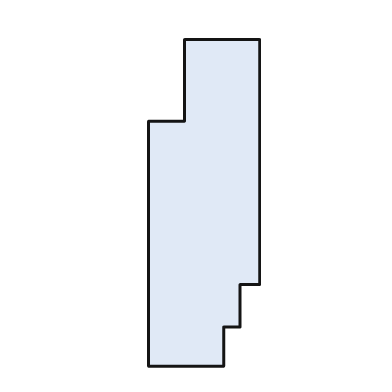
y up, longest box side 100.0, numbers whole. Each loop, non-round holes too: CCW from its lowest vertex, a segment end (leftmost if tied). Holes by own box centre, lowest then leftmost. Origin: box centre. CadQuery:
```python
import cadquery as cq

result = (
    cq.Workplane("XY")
    .moveTo(-17.0, -50.0)
    .lineTo(6.0, -50.0)
    .lineTo(6.0, -38.0)
    .lineTo(11.0, -38.0)
    .lineTo(11.0, -25.0)
    .lineTo(17.0, -25.0)
    .lineTo(17.0, 50.0)
    .lineTo(-6.0, 50.0)
    .lineTo(-6.0, 25.0)
    .lineTo(-17.0, 25.0)
    .close()
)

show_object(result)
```